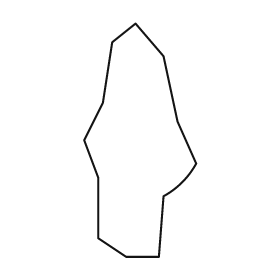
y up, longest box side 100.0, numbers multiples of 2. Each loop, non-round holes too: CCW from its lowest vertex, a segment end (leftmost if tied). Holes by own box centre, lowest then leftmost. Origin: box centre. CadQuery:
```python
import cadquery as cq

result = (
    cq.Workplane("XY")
    .moveTo(-6.0, -50.0)
    .lineTo(8.0, -50.0)
    .lineTo(10.0, -24.0)
    .threePointArc((18.0, -18.0), (24.0, -10.0))
    .lineTo(16.0, 8.0)
    .lineTo(10.0, 36.0)
    .lineTo(-2.0, 50.0)
    .lineTo(-12.0, 42.0)
    .lineTo(-16.0, 16.0)
    .lineTo(-24.0, 0.0)
    .lineTo(-18.0, -16.0)
    .lineTo(-18.0, -42.0)
    .close()
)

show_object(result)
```